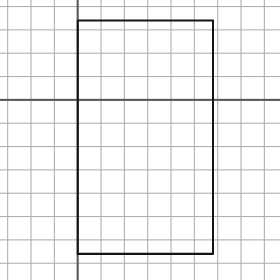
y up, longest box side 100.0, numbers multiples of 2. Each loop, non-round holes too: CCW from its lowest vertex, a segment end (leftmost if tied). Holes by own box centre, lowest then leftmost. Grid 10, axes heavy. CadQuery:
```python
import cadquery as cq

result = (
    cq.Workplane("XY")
    .moveTo(0.0, -66.0)
    .lineTo(58.0, -66.0)
    .lineTo(58.0, 34.0)
    .lineTo(0.0, 34.0)
    .close()
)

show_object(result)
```